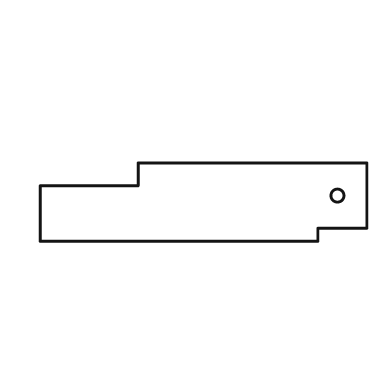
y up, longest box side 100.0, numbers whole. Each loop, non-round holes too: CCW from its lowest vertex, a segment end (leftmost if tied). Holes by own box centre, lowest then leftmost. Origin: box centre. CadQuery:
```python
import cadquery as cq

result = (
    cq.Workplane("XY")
    .moveTo(-50.0, -12.0)
    .lineTo(35.0, -12.0)
    .lineTo(35.0, -8.0)
    .lineTo(50.0, -8.0)
    .lineTo(50.0, 12.0)
    .lineTo(-20.0, 12.0)
    .lineTo(-20.0, 5.0)
    .lineTo(-50.0, 5.0)
    .close()
    .moveTo(41.0, 2.0)
    .circle(2.0)
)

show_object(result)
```